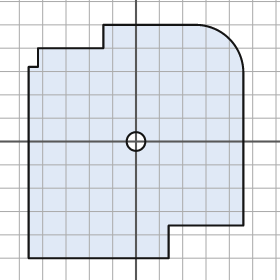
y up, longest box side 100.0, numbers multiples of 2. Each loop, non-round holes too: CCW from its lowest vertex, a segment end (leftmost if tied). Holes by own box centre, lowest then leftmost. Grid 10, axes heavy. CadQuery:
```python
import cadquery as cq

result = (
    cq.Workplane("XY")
    .moveTo(-46.0, -50.0)
    .lineTo(14.0, -50.0)
    .lineTo(14.0, -36.0)
    .lineTo(46.0, -36.0)
    .lineTo(46.0, 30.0)
    .threePointArc((40.0, 44.0), (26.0, 50.0))
    .lineTo(-14.0, 50.0)
    .lineTo(-14.0, 40.0)
    .lineTo(-42.0, 40.0)
    .lineTo(-42.0, 32.0)
    .lineTo(-46.0, 32.0)
    .close()
    .moveTo(0.0, 0.0)
    .circle(4.0)
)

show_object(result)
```